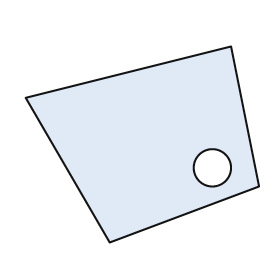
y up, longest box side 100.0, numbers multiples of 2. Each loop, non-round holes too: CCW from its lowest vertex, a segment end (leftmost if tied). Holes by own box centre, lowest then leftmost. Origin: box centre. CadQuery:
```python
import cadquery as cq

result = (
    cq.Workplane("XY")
    .moveTo(-14.0, -42.0)
    .lineTo(50.0, -18.0)
    .lineTo(38.0, 42.0)
    .lineTo(-50.0, 20.0)
    .close()
    .moveTo(30.0, -10.0)
    .circle(8.0)
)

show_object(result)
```